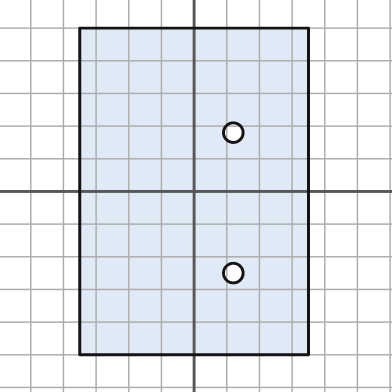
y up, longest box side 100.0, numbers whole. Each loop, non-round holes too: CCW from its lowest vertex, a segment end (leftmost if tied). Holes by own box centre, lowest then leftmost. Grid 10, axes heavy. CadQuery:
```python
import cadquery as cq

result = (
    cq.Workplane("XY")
    .moveTo(-35.0, -50.0)
    .lineTo(35.0, -50.0)
    .lineTo(35.0, 50.0)
    .lineTo(-35.0, 50.0)
    .close()
    .moveTo(12.0, -25.0)
    .circle(3.0)
    .moveTo(12.0, 18.0)
    .circle(3.0)
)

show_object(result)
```